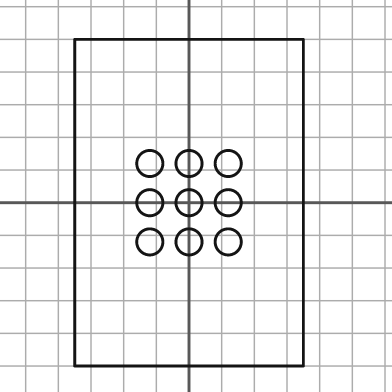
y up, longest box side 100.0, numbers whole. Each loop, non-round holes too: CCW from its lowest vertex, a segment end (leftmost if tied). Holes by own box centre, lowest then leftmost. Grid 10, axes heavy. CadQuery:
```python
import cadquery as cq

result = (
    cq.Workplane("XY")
    .moveTo(-35.0, -50.0)
    .lineTo(35.0, -50.0)
    .lineTo(35.0, 50.0)
    .lineTo(-35.0, 50.0)
    .close()
    .moveTo(-12.0, -12.0)
    .circle(4.0)
    .moveTo(0.0, -12.0)
    .circle(4.0)
    .moveTo(12.0, -12.0)
    .circle(4.0)
    .moveTo(-12.0, 0.0)
    .circle(4.0)
    .moveTo(0.0, 0.0)
    .circle(4.0)
    .moveTo(12.0, 0.0)
    .circle(4.0)
    .moveTo(-12.0, 12.0)
    .circle(4.0)
    .moveTo(0.0, 12.0)
    .circle(4.0)
    .moveTo(12.0, 12.0)
    .circle(4.0)
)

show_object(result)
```